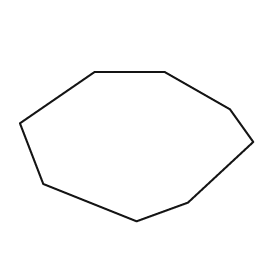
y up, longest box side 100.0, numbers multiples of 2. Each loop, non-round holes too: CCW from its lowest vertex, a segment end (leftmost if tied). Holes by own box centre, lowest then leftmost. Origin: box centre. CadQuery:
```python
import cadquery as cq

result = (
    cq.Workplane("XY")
    .moveTo(0.0, -32.0)
    .lineTo(22.0, -24.0)
    .lineTo(50.0, 2.0)
    .lineTo(40.0, 16.0)
    .lineTo(12.0, 32.0)
    .lineTo(-18.0, 32.0)
    .lineTo(-50.0, 10.0)
    .lineTo(-40.0, -16.0)
    .close()
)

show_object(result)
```